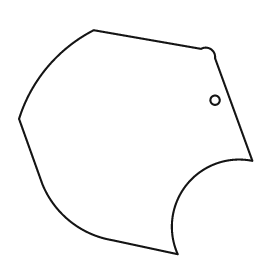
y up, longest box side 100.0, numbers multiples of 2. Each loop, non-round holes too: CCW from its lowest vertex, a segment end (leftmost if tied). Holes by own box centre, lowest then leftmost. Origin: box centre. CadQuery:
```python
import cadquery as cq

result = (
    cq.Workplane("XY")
    .moveTo(18.0, -48.0)
    .threePointArc((22.0, -18.0), (50.0, -8.0))
    .lineTo(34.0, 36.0)
    .threePointArc((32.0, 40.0), (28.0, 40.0))
    .lineTo(-18.0, 48.0)
    .threePointArc((-38.0, 32.0), (-50.0, 10.0))
    .lineTo(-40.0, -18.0)
    .threePointArc((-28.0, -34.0), (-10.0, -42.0))
    .close()
    .moveTo(34.0, 18.0)
    .circle(2.0)
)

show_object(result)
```